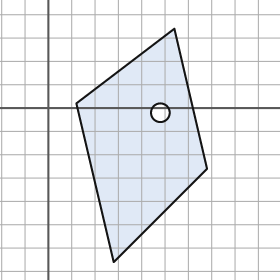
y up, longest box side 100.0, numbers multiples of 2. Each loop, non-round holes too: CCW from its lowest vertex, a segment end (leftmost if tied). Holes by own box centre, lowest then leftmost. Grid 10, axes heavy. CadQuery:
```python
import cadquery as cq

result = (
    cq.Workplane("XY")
    .moveTo(28.0, -66.0)
    .lineTo(68.0, -26.0)
    .lineTo(54.0, 34.0)
    .lineTo(12.0, 2.0)
    .close()
    .moveTo(48.0, -2.0)
    .circle(4.0)
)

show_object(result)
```